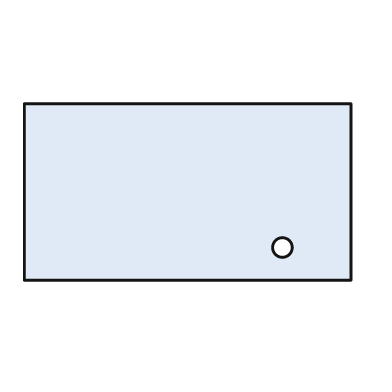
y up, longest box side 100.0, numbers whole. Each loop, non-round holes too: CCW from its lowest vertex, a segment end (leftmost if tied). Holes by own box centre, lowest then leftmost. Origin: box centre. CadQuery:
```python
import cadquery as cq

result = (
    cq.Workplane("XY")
    .moveTo(-50.0, -27.0)
    .lineTo(50.0, -27.0)
    .lineTo(50.0, 27.0)
    .lineTo(-50.0, 27.0)
    .close()
    .moveTo(29.0, -17.0)
    .circle(3.0)
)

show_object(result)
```